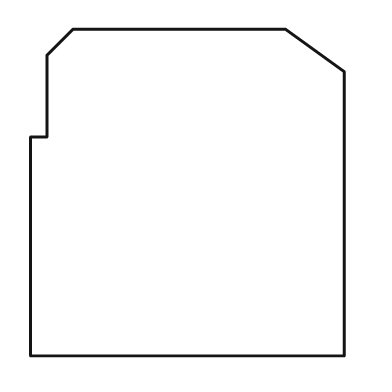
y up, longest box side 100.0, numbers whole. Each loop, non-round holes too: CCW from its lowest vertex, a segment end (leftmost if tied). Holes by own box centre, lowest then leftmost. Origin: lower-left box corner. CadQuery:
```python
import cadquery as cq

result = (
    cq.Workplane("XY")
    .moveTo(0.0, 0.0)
    .lineTo(96.0, 0.0)
    .lineTo(96.0, 87.0)
    .lineTo(78.0, 100.0)
    .lineTo(13.0, 100.0)
    .lineTo(5.0, 92.0)
    .lineTo(5.0, 67.0)
    .lineTo(0.0, 67.0)
    .close()
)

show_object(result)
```